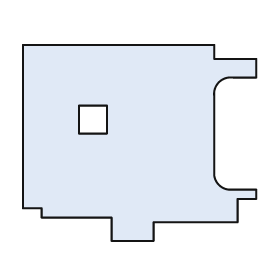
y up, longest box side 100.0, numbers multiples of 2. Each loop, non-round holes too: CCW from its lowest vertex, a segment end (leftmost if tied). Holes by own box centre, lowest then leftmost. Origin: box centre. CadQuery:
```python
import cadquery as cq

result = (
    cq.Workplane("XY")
    .moveTo(-12.0, -42.0)
    .lineTo(6.0, -42.0)
    .lineTo(6.0, -34.0)
    .lineTo(42.0, -34.0)
    .lineTo(42.0, -24.0)
    .lineTo(50.0, -24.0)
    .lineTo(50.0, -20.0)
    .lineTo(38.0, -20.0)
    .threePointArc((34.0, -18.0), (32.0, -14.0))
    .lineTo(32.0, 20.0)
    .threePointArc((34.0, 26.0), (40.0, 28.0))
    .lineTo(50.0, 28.0)
    .lineTo(50.0, 36.0)
    .lineTo(32.0, 36.0)
    .lineTo(32.0, 42.0)
    .lineTo(-50.0, 42.0)
    .lineTo(-50.0, -28.0)
    .lineTo(-42.0, -28.0)
    .lineTo(-42.0, -32.0)
    .lineTo(-12.0, -32.0)
    .close()
    .moveTo(-26.0, 4.0)
    .lineTo(-14.0, 4.0)
    .lineTo(-14.0, 16.0)
    .lineTo(-26.0, 16.0)
    .close()
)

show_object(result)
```